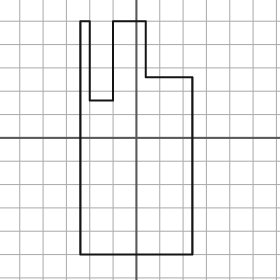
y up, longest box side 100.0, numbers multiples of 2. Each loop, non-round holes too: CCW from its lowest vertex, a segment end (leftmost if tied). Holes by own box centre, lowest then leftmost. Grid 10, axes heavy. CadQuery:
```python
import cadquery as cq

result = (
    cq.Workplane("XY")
    .moveTo(-24.0, -50.0)
    .lineTo(24.0, -50.0)
    .lineTo(24.0, 26.0)
    .lineTo(4.0, 26.0)
    .lineTo(4.0, 50.0)
    .lineTo(-10.0, 50.0)
    .lineTo(-10.0, 16.0)
    .lineTo(-20.0, 16.0)
    .lineTo(-20.0, 50.0)
    .lineTo(-24.0, 50.0)
    .close()
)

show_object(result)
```